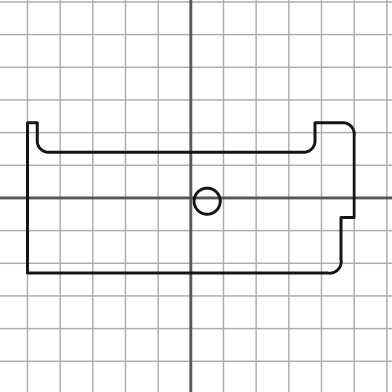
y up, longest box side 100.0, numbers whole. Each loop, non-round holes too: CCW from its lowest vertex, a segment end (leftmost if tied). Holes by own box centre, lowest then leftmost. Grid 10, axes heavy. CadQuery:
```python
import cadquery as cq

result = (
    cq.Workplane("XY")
    .moveTo(-50.0, -23.0)
    .lineTo(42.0, -23.0)
    .threePointArc((45.0, -22.0), (46.0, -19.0))
    .lineTo(46.0, -6.0)
    .lineTo(50.0, -6.0)
    .lineTo(50.0, 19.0)
    .threePointArc((49.0, 22.0), (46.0, 23.0))
    .lineTo(38.0, 23.0)
    .lineTo(38.0, 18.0)
    .threePointArc((37.0, 15.0), (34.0, 14.0))
    .lineTo(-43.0, 14.0)
    .threePointArc((-46.0, 15.0), (-47.0, 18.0))
    .lineTo(-47.0, 23.0)
    .lineTo(-50.0, 23.0)
    .close()
    .moveTo(5.0, -1.0)
    .circle(4.0)
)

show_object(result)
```